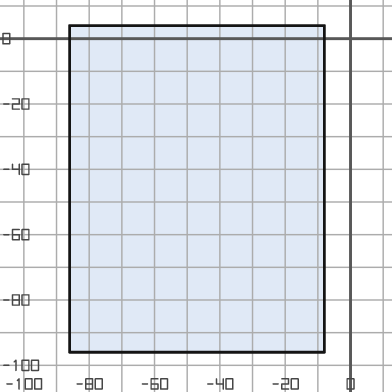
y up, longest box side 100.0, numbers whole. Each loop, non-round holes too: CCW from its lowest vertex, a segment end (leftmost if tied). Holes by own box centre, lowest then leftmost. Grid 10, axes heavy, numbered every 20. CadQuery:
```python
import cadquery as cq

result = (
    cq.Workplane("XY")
    .moveTo(-86.0, -96.0)
    .lineTo(-8.0, -96.0)
    .lineTo(-8.0, 4.0)
    .lineTo(-86.0, 4.0)
    .close()
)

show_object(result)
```